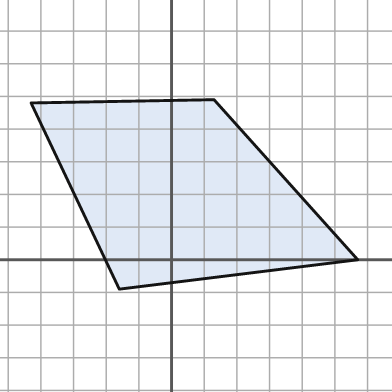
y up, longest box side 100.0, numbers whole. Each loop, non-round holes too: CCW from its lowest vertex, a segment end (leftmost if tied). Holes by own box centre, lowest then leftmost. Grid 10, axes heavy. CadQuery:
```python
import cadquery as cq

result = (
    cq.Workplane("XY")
    .moveTo(-16.0, -9.0)
    .lineTo(57.0, 0.0)
    .lineTo(13.0, 49.0)
    .lineTo(-43.0, 48.0)
    .close()
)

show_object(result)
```